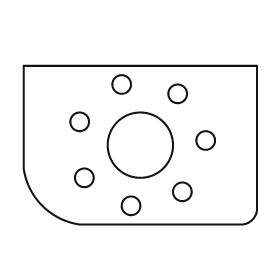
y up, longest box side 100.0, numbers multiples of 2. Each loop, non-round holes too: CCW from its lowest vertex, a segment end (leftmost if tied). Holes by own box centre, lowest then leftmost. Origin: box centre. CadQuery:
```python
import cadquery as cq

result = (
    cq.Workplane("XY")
    .moveTo(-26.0, -34.0)
    .lineTo(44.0, -34.0)
    .threePointArc((48.0, -32.0), (50.0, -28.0))
    .lineTo(50.0, 34.0)
    .lineTo(-50.0, 34.0)
    .lineTo(-50.0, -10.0)
    .threePointArc((-42.0, -26.0), (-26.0, -34.0))
    .close()
    .moveTo(-4.0, -26.0)
    .circle(4.0)
    .moveTo(18.0, -20.0)
    .circle(4.0)
    .moveTo(-24.0, -14.0)
    .circle(4.0)
    .moveTo(0.0, 0.0)
    .circle(14.0)
    .moveTo(28.0, 2.0)
    .circle(4.0)
    .moveTo(-26.0, 10.0)
    .circle(4.0)
    .moveTo(16.0, 22.0)
    .circle(4.0)
    .moveTo(-8.0, 26.0)
    .circle(4.0)
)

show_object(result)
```